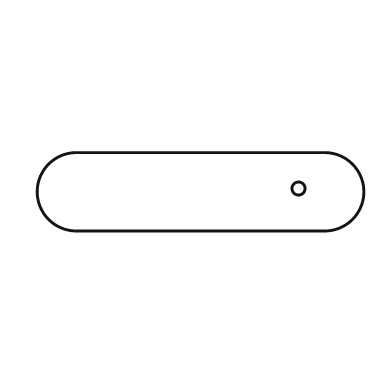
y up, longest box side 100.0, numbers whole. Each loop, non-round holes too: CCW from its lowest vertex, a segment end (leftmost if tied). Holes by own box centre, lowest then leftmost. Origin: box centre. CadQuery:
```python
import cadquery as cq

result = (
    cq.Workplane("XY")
    .moveTo(-38.0, -12.0)
    .lineTo(38.0, -12.0)
    .threePointArc((50.0, 0.0), (38.0, 12.0))
    .lineTo(-38.0, 12.0)
    .threePointArc((-50.0, 0.0), (-38.0, -12.0))
    .close()
    .moveTo(30.0, 1.0)
    .circle(2.0)
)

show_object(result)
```